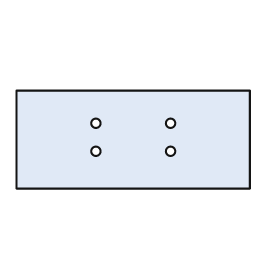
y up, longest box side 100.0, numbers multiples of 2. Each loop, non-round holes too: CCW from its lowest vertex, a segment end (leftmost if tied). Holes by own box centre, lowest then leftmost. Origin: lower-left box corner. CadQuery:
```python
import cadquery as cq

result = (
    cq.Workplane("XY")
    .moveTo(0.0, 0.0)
    .lineTo(100.0, 0.0)
    .lineTo(100.0, 42.0)
    .lineTo(0.0, 42.0)
    .close()
    .moveTo(34.0, 16.0)
    .circle(2.0)
    .moveTo(66.0, 16.0)
    .circle(2.0)
    .moveTo(34.0, 28.0)
    .circle(2.0)
    .moveTo(66.0, 28.0)
    .circle(2.0)
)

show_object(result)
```